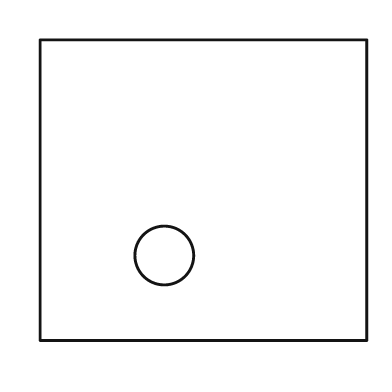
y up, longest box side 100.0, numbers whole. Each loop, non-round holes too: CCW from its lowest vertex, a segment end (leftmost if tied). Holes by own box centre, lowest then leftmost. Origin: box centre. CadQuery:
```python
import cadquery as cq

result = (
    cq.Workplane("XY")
    .moveTo(-50.0, -46.0)
    .lineTo(50.0, -46.0)
    .lineTo(50.0, 46.0)
    .lineTo(-50.0, 46.0)
    .close()
    .moveTo(-12.0, -20.0)
    .circle(9.0)
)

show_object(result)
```